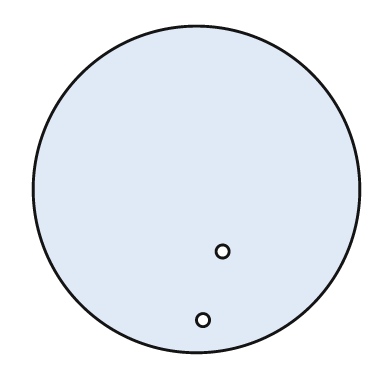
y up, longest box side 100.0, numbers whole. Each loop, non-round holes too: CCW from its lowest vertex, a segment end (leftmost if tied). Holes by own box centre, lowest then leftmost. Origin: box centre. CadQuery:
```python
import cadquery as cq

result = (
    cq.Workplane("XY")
    .moveTo(0.0, 0.0)
    .circle(50.0)
    .moveTo(2.0, -40.0)
    .circle(2.0)
    .moveTo(8.0, -19.0)
    .circle(2.0)
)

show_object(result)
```